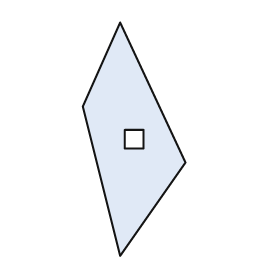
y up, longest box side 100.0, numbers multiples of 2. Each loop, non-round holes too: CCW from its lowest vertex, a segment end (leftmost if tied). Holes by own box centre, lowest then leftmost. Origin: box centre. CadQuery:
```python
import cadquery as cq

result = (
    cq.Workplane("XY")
    .moveTo(-6.0, -50.0)
    .lineTo(22.0, -10.0)
    .lineTo(-6.0, 50.0)
    .lineTo(-22.0, 14.0)
    .close()
    .moveTo(-4.0, -4.0)
    .lineTo(4.0, -4.0)
    .lineTo(4.0, 4.0)
    .lineTo(-4.0, 4.0)
    .close()
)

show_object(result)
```